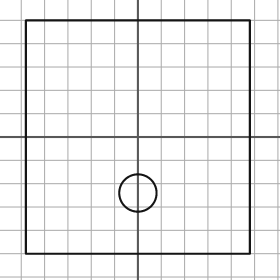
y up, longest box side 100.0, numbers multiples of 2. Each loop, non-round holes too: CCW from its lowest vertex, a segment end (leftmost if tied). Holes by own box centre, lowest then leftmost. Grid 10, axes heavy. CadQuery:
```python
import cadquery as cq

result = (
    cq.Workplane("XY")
    .moveTo(-48.0, -50.0)
    .lineTo(48.0, -50.0)
    .lineTo(48.0, 50.0)
    .lineTo(-48.0, 50.0)
    .close()
    .moveTo(0.0, -24.0)
    .circle(8.0)
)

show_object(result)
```